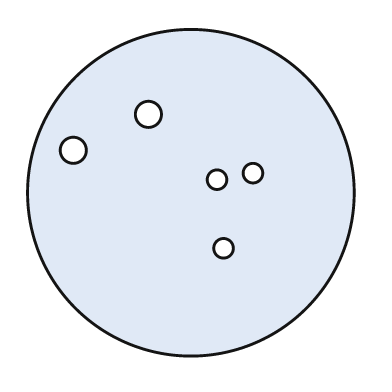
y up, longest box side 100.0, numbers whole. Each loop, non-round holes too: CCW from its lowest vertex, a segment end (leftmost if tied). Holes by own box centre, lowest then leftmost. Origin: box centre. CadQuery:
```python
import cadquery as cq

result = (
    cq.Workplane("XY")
    .moveTo(0.0, 0.0)
    .circle(50.0)
    .moveTo(10.0, -17.0)
    .circle(3.0)
    .moveTo(8.0, 4.0)
    .circle(3.0)
    .moveTo(19.0, 6.0)
    .circle(3.0)
    .moveTo(-36.0, 13.0)
    .circle(4.0)
    .moveTo(-13.0, 24.0)
    .circle(4.0)
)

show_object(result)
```